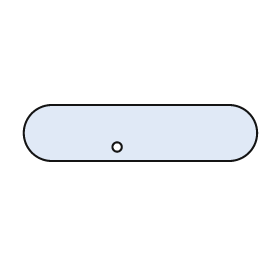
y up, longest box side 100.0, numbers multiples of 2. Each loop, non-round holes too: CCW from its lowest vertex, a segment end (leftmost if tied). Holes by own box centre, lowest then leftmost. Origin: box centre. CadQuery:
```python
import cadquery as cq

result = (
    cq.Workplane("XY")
    .moveTo(-38.0, -12.0)
    .lineTo(38.0, -12.0)
    .threePointArc((50.0, 0.0), (38.0, 12.0))
    .lineTo(-38.0, 12.0)
    .threePointArc((-50.0, 0.0), (-38.0, -12.0))
    .close()
    .moveTo(-10.0, -6.0)
    .circle(2.0)
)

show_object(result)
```